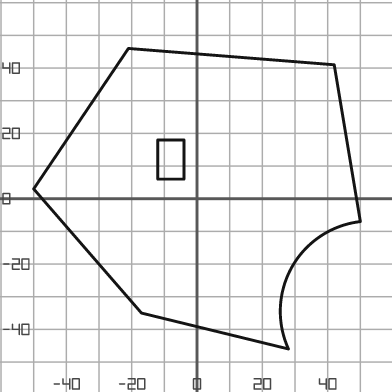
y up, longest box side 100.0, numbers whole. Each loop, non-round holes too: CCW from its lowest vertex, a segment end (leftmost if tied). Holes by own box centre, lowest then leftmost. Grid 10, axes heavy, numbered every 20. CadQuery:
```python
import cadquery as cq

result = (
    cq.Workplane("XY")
    .moveTo(28.0, -46.0)
    .threePointArc((29.0, -21.0), (50.0, -7.0))
    .lineTo(42.0, 41.0)
    .lineTo(-21.0, 46.0)
    .lineTo(-50.0, 3.0)
    .lineTo(-17.0, -35.0)
    .close()
    .moveTo(-12.0, 6.0)
    .lineTo(-4.0, 6.0)
    .lineTo(-4.0, 18.0)
    .lineTo(-12.0, 18.0)
    .close()
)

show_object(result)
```